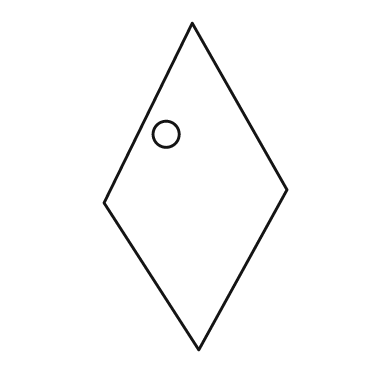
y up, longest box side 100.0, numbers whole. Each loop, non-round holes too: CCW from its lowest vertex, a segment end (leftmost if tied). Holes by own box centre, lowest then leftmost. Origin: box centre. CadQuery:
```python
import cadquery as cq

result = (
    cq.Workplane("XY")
    .moveTo(1.0, -50.0)
    .lineTo(28.0, -1.0)
    .lineTo(-1.0, 50.0)
    .lineTo(-28.0, -5.0)
    .close()
    .moveTo(-9.0, 16.0)
    .circle(4.0)
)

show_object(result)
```